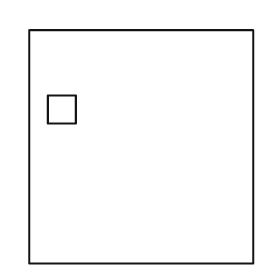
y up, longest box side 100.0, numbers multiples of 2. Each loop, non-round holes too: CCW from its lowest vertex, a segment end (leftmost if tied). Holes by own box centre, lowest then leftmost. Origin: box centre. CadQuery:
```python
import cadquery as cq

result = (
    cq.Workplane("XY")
    .moveTo(-48.0, -50.0)
    .lineTo(48.0, -50.0)
    .lineTo(48.0, 50.0)
    .lineTo(-48.0, 50.0)
    .close()
    .moveTo(-40.0, 10.0)
    .lineTo(-28.0, 10.0)
    .lineTo(-28.0, 22.0)
    .lineTo(-40.0, 22.0)
    .close()
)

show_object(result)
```